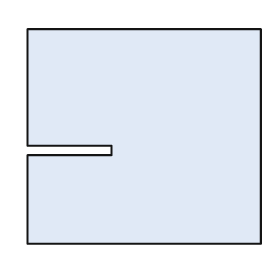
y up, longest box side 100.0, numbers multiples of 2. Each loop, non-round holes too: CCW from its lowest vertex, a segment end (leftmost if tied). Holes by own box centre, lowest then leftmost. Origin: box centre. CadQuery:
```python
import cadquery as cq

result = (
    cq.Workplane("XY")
    .moveTo(-50.0, -46.0)
    .lineTo(50.0, -46.0)
    .lineTo(50.0, 46.0)
    .lineTo(-50.0, 46.0)
    .lineTo(-50.0, -4.0)
    .lineTo(-14.0, -4.0)
    .lineTo(-14.0, -8.0)
    .lineTo(-50.0, -8.0)
    .close()
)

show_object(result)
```